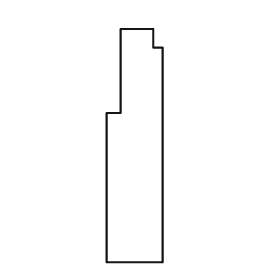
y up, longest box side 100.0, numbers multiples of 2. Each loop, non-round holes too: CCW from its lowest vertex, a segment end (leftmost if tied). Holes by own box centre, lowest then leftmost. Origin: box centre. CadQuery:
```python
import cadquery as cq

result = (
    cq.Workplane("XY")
    .moveTo(-12.0, -50.0)
    .lineTo(12.0, -50.0)
    .lineTo(12.0, 42.0)
    .lineTo(8.0, 42.0)
    .lineTo(8.0, 50.0)
    .lineTo(-6.0, 50.0)
    .lineTo(-6.0, 14.0)
    .lineTo(-12.0, 14.0)
    .close()
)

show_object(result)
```